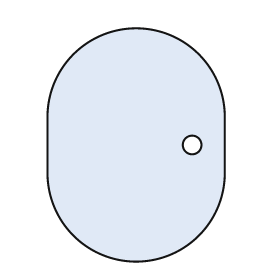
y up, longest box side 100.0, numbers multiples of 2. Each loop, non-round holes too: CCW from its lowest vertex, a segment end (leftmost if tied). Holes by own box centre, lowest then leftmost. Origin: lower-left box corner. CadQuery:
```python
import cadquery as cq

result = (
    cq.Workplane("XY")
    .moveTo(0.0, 38.0)
    .threePointArc((38.0, 0.0), (76.0, 38.0))
    .lineTo(76.0, 62.0)
    .threePointArc((38.0, 100.0), (0.0, 62.0))
    .close()
    .moveTo(62.0, 50.0)
    .circle(4.0)
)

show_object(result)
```